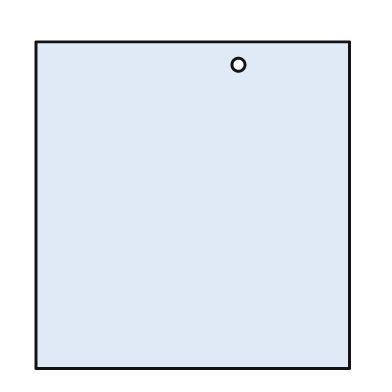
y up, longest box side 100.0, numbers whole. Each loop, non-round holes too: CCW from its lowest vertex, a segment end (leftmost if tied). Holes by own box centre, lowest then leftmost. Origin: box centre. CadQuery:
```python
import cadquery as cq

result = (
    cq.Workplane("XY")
    .moveTo(-48.0, -50.0)
    .lineTo(48.0, -50.0)
    .lineTo(48.0, 50.0)
    .lineTo(-48.0, 50.0)
    .close()
    .moveTo(14.0, 43.0)
    .circle(2.0)
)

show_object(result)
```